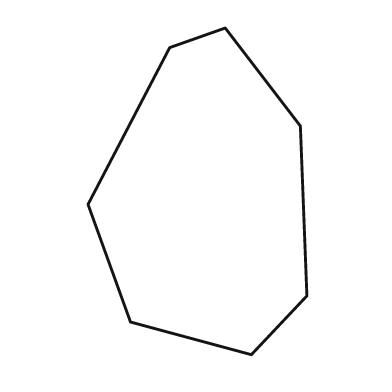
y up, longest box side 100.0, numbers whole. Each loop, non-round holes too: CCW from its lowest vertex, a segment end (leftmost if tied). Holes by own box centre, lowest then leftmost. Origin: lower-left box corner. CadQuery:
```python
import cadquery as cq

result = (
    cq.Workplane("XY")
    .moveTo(50.0, 0.0)
    .lineTo(67.0, 18.0)
    .lineTo(65.0, 70.0)
    .lineTo(42.0, 100.0)
    .lineTo(25.0, 94.0)
    .lineTo(0.0, 46.0)
    .lineTo(13.0, 10.0)
    .close()
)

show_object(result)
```